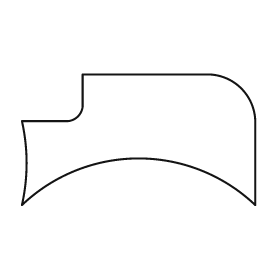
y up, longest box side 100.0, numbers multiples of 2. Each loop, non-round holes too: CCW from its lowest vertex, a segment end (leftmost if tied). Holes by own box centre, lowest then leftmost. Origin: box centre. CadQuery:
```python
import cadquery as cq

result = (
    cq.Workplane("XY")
    .moveTo(-50.0, -28.0)
    .threePointArc((0.0, -8.0), (50.0, -28.0))
    .lineTo(50.0, 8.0)
    .threePointArc((44.0, 22.0), (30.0, 28.0))
    .lineTo(-24.0, 28.0)
    .lineTo(-24.0, 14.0)
    .threePointArc((-26.0, 10.0), (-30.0, 8.0))
    .lineTo(-50.0, 8.0)
    .threePointArc((-48.0, -10.0), (-50.0, -28.0))
    .close()
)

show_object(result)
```